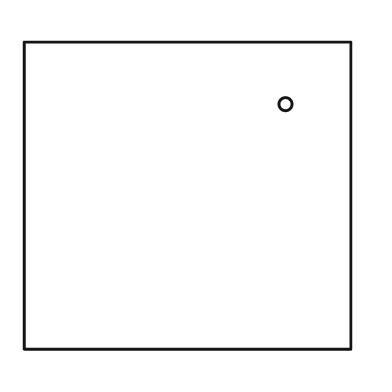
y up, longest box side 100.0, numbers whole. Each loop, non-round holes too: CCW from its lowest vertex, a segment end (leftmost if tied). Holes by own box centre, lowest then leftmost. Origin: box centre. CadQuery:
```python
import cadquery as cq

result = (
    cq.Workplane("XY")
    .moveTo(-50.0, -47.0)
    .lineTo(50.0, -47.0)
    .lineTo(50.0, 47.0)
    .lineTo(-50.0, 47.0)
    .close()
    .moveTo(30.0, 28.0)
    .circle(2.0)
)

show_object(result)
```